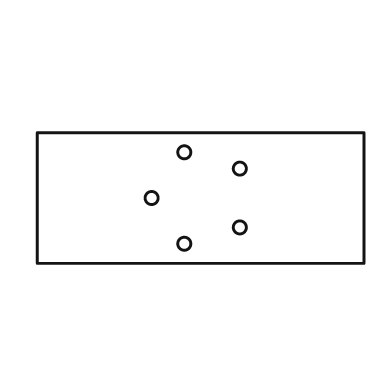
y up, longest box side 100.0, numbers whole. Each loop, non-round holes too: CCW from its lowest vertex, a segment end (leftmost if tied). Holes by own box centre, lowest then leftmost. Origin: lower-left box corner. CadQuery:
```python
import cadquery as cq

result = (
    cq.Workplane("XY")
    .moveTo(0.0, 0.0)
    .lineTo(100.0, 0.0)
    .lineTo(100.0, 40.0)
    .lineTo(0.0, 40.0)
    .close()
    .moveTo(45.0, 6.0)
    .circle(2.0)
    .moveTo(62.0, 11.0)
    .circle(2.0)
    .moveTo(35.0, 20.0)
    .circle(2.0)
    .moveTo(62.0, 29.0)
    .circle(2.0)
    .moveTo(45.0, 34.0)
    .circle(2.0)
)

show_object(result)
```